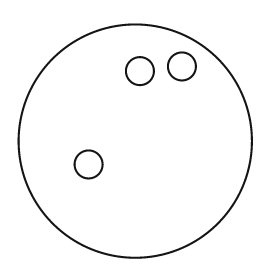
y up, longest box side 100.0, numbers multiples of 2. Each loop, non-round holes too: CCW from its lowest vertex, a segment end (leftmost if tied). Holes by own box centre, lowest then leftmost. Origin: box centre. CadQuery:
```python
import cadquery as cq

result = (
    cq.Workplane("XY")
    .moveTo(0.0, 0.0)
    .circle(50.0)
    .moveTo(-20.0, -10.0)
    .circle(6.0)
    .moveTo(2.0, 30.0)
    .circle(6.0)
    .moveTo(20.0, 32.0)
    .circle(6.0)
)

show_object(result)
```